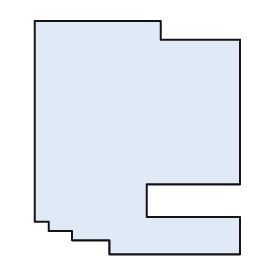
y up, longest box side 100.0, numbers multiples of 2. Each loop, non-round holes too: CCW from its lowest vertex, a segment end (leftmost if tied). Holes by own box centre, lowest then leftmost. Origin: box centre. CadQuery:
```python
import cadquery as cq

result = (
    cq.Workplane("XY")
    .moveTo(-12.0, -50.0)
    .lineTo(44.0, -50.0)
    .lineTo(44.0, -34.0)
    .lineTo(4.0, -34.0)
    .lineTo(4.0, -20.0)
    .lineTo(44.0, -20.0)
    .lineTo(44.0, 42.0)
    .lineTo(10.0, 42.0)
    .lineTo(10.0, 50.0)
    .lineTo(-44.0, 50.0)
    .lineTo(-44.0, -36.0)
    .lineTo(-38.0, -36.0)
    .lineTo(-38.0, -40.0)
    .lineTo(-28.0, -40.0)
    .lineTo(-28.0, -44.0)
    .lineTo(-12.0, -44.0)
    .close()
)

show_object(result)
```